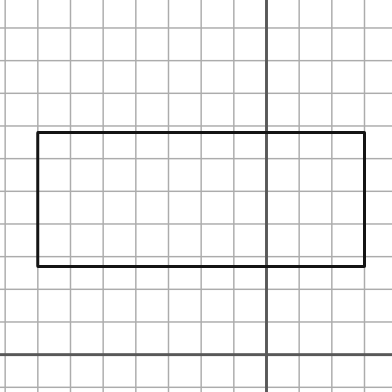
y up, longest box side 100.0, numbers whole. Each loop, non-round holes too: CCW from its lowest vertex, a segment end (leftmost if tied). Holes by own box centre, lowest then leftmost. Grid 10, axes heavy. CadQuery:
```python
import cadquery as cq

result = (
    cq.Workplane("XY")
    .moveTo(-70.0, 27.0)
    .lineTo(30.0, 27.0)
    .lineTo(30.0, 68.0)
    .lineTo(-70.0, 68.0)
    .close()
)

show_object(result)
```